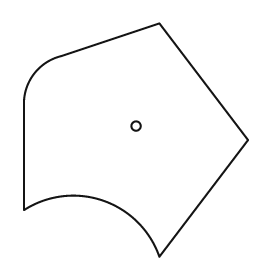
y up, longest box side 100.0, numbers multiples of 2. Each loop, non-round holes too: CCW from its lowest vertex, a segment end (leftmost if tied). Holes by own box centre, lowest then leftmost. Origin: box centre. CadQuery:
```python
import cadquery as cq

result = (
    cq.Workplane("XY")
    .moveTo(10.0, -50.0)
    .lineTo(48.0, 0.0)
    .lineTo(10.0, 50.0)
    .lineTo(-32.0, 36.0)
    .threePointArc((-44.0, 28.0), (-48.0, 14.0))
    .lineTo(-48.0, -30.0)
    .threePointArc((-14.0, -26.0), (10.0, -50.0))
    .close()
    .moveTo(0.0, 6.0)
    .circle(2.0)
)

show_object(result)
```